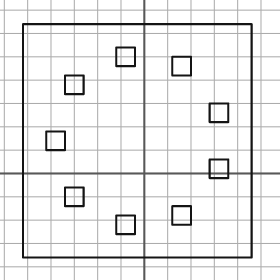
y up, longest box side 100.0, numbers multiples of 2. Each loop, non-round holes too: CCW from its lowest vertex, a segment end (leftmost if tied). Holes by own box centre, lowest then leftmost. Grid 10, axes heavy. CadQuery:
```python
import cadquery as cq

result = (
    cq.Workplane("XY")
    .moveTo(-52.0, -36.0)
    .lineTo(46.0, -36.0)
    .lineTo(46.0, 64.0)
    .lineTo(-52.0, 64.0)
    .close()
    .moveTo(-12.0, -26.0)
    .lineTo(-4.0, -26.0)
    .lineTo(-4.0, -18.0)
    .lineTo(-12.0, -18.0)
    .close()
    .moveTo(12.0, -22.0)
    .lineTo(20.0, -22.0)
    .lineTo(20.0, -14.0)
    .lineTo(12.0, -14.0)
    .close()
    .moveTo(-34.0, -14.0)
    .lineTo(-26.0, -14.0)
    .lineTo(-26.0, -6.0)
    .lineTo(-34.0, -6.0)
    .close()
    .moveTo(28.0, -2.0)
    .lineTo(36.0, -2.0)
    .lineTo(36.0, 6.0)
    .lineTo(28.0, 6.0)
    .close()
    .moveTo(-42.0, 10.0)
    .lineTo(-34.0, 10.0)
    .lineTo(-34.0, 18.0)
    .lineTo(-42.0, 18.0)
    .close()
    .moveTo(28.0, 22.0)
    .lineTo(36.0, 22.0)
    .lineTo(36.0, 30.0)
    .lineTo(28.0, 30.0)
    .close()
    .moveTo(-34.0, 34.0)
    .lineTo(-26.0, 34.0)
    .lineTo(-26.0, 42.0)
    .lineTo(-34.0, 42.0)
    .close()
    .moveTo(12.0, 42.0)
    .lineTo(20.0, 42.0)
    .lineTo(20.0, 50.0)
    .lineTo(12.0, 50.0)
    .close()
    .moveTo(-12.0, 46.0)
    .lineTo(-4.0, 46.0)
    .lineTo(-4.0, 54.0)
    .lineTo(-12.0, 54.0)
    .close()
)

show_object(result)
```